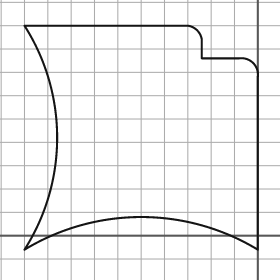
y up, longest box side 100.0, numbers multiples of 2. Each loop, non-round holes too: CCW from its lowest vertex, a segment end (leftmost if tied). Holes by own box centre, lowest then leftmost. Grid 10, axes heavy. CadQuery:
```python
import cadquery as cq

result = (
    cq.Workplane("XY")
    .moveTo(-100.0, -6.0)
    .threePointArc((-50.0, 8.0), (0.0, -6.0))
    .lineTo(0.0, 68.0)
    .threePointArc((-2.0, 74.0), (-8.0, 76.0))
    .lineTo(-24.0, 76.0)
    .lineTo(-24.0, 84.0)
    .threePointArc((-26.0, 88.0), (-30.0, 90.0))
    .lineTo(-100.0, 90.0)
    .threePointArc((-86.0, 42.0), (-100.0, -6.0))
    .close()
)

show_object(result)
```